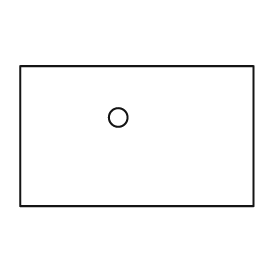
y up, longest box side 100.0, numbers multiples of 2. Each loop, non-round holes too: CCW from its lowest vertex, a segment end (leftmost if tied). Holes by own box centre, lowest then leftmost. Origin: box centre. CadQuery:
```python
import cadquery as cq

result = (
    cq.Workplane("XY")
    .moveTo(-50.0, -30.0)
    .lineTo(50.0, -30.0)
    .lineTo(50.0, 30.0)
    .lineTo(-50.0, 30.0)
    .close()
    .moveTo(-8.0, 8.0)
    .circle(4.0)
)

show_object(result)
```